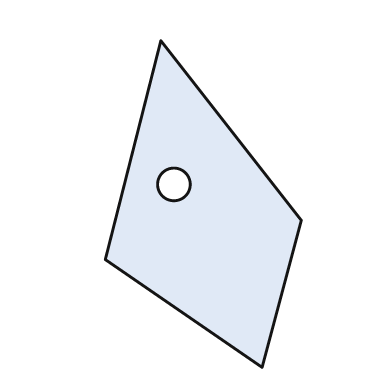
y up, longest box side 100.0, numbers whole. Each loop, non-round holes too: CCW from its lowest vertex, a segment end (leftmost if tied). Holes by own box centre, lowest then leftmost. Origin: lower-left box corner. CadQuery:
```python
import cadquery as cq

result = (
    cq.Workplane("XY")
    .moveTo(48.0, 0.0)
    .lineTo(60.0, 45.0)
    .lineTo(17.0, 100.0)
    .lineTo(0.0, 33.0)
    .close()
    .moveTo(21.0, 56.0)
    .circle(5.0)
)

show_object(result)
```